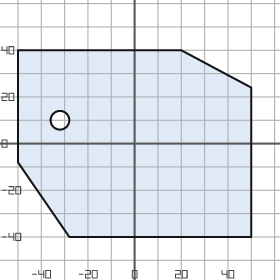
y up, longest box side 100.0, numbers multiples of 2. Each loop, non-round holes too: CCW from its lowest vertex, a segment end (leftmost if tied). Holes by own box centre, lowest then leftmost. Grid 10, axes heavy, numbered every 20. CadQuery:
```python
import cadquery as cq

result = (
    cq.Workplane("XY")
    .moveTo(-28.0, -40.0)
    .lineTo(50.0, -40.0)
    .lineTo(50.0, 24.0)
    .lineTo(20.0, 40.0)
    .lineTo(-50.0, 40.0)
    .lineTo(-50.0, -8.0)
    .close()
    .moveTo(-32.0, 10.0)
    .circle(4.0)
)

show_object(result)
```